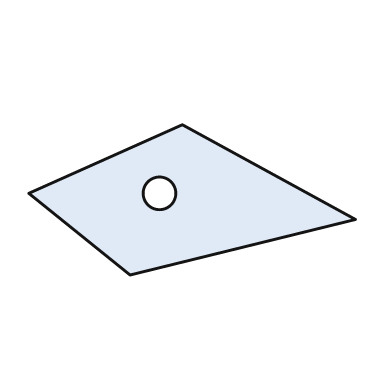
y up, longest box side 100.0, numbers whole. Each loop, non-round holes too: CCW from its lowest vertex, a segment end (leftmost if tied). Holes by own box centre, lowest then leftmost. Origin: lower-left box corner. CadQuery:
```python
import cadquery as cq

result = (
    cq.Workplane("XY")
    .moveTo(31.0, 0.0)
    .lineTo(100.0, 17.0)
    .lineTo(47.0, 46.0)
    .lineTo(0.0, 25.0)
    .close()
    .moveTo(40.0, 25.0)
    .circle(5.0)
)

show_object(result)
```